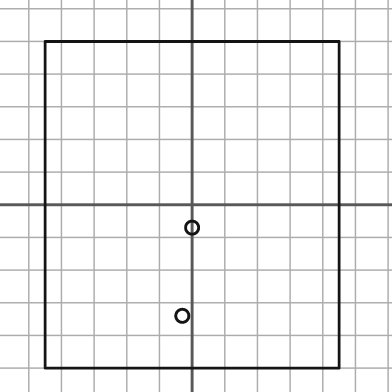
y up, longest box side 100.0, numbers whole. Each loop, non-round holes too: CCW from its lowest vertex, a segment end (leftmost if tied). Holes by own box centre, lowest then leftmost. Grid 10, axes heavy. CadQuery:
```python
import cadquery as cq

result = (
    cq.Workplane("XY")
    .moveTo(-45.0, -50.0)
    .lineTo(45.0, -50.0)
    .lineTo(45.0, 50.0)
    .lineTo(-45.0, 50.0)
    .close()
    .moveTo(-3.0, -34.0)
    .circle(2.0)
    .moveTo(0.0, -7.0)
    .circle(2.0)
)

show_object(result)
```